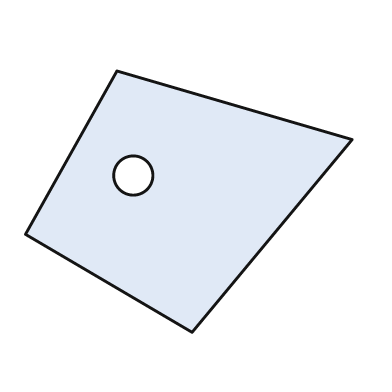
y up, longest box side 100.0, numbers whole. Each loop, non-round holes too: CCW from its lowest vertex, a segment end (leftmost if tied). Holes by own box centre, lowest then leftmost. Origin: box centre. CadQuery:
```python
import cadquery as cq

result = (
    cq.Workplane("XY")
    .moveTo(1.0, -40.0)
    .lineTo(50.0, 19.0)
    .lineTo(-22.0, 40.0)
    .lineTo(-50.0, -10.0)
    .close()
    .moveTo(-17.0, 8.0)
    .circle(6.0)
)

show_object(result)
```